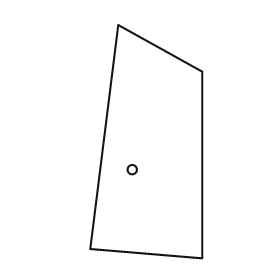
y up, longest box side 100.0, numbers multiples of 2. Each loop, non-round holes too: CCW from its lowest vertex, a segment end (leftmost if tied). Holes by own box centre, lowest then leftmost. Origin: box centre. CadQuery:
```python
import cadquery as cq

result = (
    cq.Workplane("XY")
    .moveTo(24.0, -50.0)
    .lineTo(24.0, 30.0)
    .lineTo(-12.0, 50.0)
    .lineTo(-24.0, -46.0)
    .close()
    .moveTo(-6.0, -12.0)
    .circle(2.0)
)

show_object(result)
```